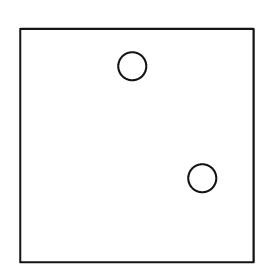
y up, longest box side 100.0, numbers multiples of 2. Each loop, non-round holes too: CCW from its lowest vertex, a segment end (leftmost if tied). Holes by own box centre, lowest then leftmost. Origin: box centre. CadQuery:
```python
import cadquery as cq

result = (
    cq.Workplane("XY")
    .moveTo(-50.0, -50.0)
    .lineTo(50.0, -50.0)
    .lineTo(50.0, 50.0)
    .lineTo(-50.0, 50.0)
    .close()
    .moveTo(28.0, -14.0)
    .circle(6.0)
    .moveTo(-2.0, 34.0)
    .circle(6.0)
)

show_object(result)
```